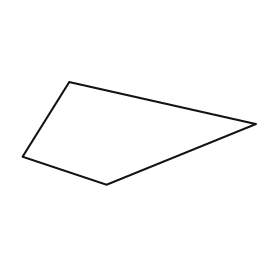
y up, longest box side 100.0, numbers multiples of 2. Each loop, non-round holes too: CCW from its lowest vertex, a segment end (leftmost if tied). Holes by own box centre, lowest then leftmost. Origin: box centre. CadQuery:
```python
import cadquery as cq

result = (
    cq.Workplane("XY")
    .moveTo(-14.0, -22.0)
    .lineTo(50.0, 4.0)
    .lineTo(-30.0, 22.0)
    .lineTo(-50.0, -10.0)
    .close()
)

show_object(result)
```